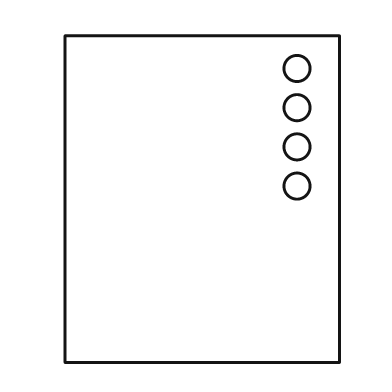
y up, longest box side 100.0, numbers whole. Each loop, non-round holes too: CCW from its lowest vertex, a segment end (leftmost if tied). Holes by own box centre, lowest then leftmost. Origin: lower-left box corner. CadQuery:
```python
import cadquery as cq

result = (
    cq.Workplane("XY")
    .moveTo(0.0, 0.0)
    .lineTo(84.0, 0.0)
    .lineTo(84.0, 100.0)
    .lineTo(0.0, 100.0)
    .close()
    .moveTo(71.0, 54.0)
    .circle(4.0)
    .moveTo(71.0, 66.0)
    .circle(4.0)
    .moveTo(71.0, 78.0)
    .circle(4.0)
    .moveTo(71.0, 90.0)
    .circle(4.0)
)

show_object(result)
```